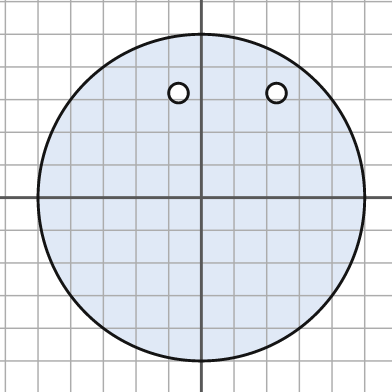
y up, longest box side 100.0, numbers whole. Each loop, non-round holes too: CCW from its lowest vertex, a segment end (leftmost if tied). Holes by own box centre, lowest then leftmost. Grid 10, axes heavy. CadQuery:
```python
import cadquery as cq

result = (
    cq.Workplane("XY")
    .moveTo(0.0, 0.0)
    .circle(50.0)
    .moveTo(-7.0, 32.0)
    .circle(3.0)
    .moveTo(23.0, 32.0)
    .circle(3.0)
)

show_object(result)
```